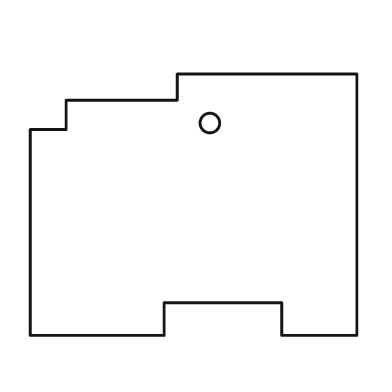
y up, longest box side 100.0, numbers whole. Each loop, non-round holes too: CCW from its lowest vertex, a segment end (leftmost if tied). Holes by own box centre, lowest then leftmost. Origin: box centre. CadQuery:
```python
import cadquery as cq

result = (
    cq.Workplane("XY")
    .moveTo(-50.0, -40.0)
    .lineTo(-9.0, -40.0)
    .lineTo(-9.0, -30.0)
    .lineTo(27.0, -30.0)
    .lineTo(27.0, -40.0)
    .lineTo(50.0, -40.0)
    .lineTo(50.0, 40.0)
    .lineTo(-5.0, 40.0)
    .lineTo(-5.0, 32.0)
    .lineTo(-39.0, 32.0)
    .lineTo(-39.0, 23.0)
    .lineTo(-50.0, 23.0)
    .close()
    .moveTo(5.0, 25.0)
    .circle(3.0)
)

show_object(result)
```